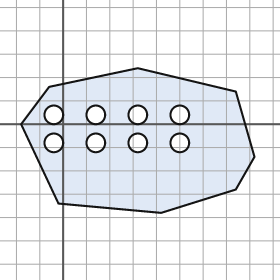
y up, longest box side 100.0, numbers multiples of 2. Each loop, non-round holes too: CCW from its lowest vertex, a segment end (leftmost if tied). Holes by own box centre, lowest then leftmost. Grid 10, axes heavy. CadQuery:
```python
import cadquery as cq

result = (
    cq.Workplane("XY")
    .moveTo(42.0, -38.0)
    .lineTo(74.0, -28.0)
    .lineTo(82.0, -14.0)
    .lineTo(74.0, 14.0)
    .lineTo(32.0, 24.0)
    .lineTo(-6.0, 16.0)
    .lineTo(-18.0, 0.0)
    .lineTo(-2.0, -34.0)
    .close()
    .moveTo(-4.0, -8.0)
    .circle(4.0)
    .moveTo(14.0, -8.0)
    .circle(4.0)
    .moveTo(32.0, -8.0)
    .circle(4.0)
    .moveTo(50.0, -8.0)
    .circle(4.0)
    .moveTo(-4.0, 4.0)
    .circle(4.0)
    .moveTo(14.0, 4.0)
    .circle(4.0)
    .moveTo(32.0, 4.0)
    .circle(4.0)
    .moveTo(50.0, 4.0)
    .circle(4.0)
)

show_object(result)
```